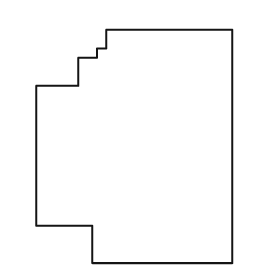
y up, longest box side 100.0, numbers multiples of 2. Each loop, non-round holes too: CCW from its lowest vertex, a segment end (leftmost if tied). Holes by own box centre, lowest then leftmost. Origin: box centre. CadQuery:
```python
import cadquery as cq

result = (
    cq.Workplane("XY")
    .moveTo(-18.0, -50.0)
    .lineTo(42.0, -50.0)
    .lineTo(42.0, 50.0)
    .lineTo(-12.0, 50.0)
    .lineTo(-12.0, 42.0)
    .lineTo(-16.0, 42.0)
    .lineTo(-16.0, 38.0)
    .lineTo(-24.0, 38.0)
    .lineTo(-24.0, 26.0)
    .lineTo(-42.0, 26.0)
    .lineTo(-42.0, -34.0)
    .lineTo(-18.0, -34.0)
    .close()
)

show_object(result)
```